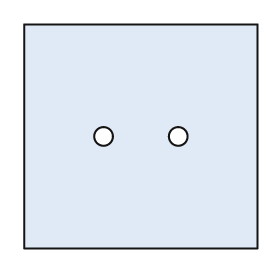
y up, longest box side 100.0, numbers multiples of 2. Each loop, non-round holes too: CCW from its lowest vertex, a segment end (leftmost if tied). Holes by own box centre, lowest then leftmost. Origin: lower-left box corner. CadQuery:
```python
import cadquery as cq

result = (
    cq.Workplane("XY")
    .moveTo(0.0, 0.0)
    .lineTo(100.0, 0.0)
    .lineTo(100.0, 96.0)
    .lineTo(0.0, 96.0)
    .close()
    .moveTo(34.0, 48.0)
    .circle(4.0)
    .moveTo(66.0, 48.0)
    .circle(4.0)
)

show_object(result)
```